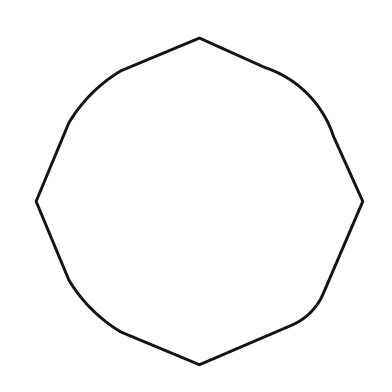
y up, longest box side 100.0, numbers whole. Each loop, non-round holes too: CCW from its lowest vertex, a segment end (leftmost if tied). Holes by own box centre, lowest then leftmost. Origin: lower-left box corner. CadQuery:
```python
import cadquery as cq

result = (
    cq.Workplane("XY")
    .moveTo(50.0, 0.0)
    .lineTo(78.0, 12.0)
    .threePointArc((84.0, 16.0), (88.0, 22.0))
    .lineTo(100.0, 50.0)
    .lineTo(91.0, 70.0)
    .threePointArc((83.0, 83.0), (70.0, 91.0))
    .lineTo(50.0, 100.0)
    .lineTo(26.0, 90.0)
    .threePointArc((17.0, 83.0), (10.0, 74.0))
    .lineTo(0.0, 50.0)
    .lineTo(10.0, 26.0)
    .threePointArc((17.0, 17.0), (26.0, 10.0))
    .close()
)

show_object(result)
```